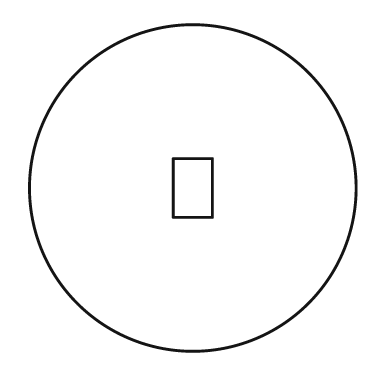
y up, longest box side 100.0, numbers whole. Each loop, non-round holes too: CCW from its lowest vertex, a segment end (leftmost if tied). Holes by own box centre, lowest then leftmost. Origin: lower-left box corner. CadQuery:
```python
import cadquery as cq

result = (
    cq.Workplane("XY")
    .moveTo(50.0, 50.0)
    .circle(50.0)
    .moveTo(44.0, 41.0)
    .lineTo(56.0, 41.0)
    .lineTo(56.0, 59.0)
    .lineTo(44.0, 59.0)
    .close()
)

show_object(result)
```